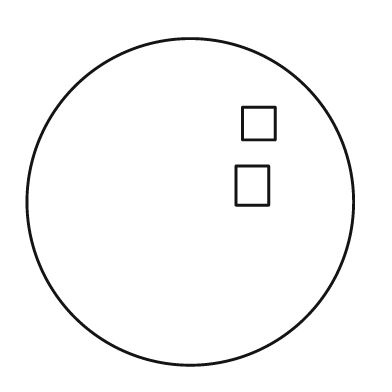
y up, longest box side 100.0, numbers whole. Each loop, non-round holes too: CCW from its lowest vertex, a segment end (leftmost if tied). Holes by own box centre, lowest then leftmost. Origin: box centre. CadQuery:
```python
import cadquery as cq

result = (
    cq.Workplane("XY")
    .moveTo(0.0, 0.0)
    .circle(50.0)
    .moveTo(14.0, -1.0)
    .lineTo(24.0, -1.0)
    .lineTo(24.0, 11.0)
    .lineTo(14.0, 11.0)
    .close()
    .moveTo(16.0, 19.0)
    .lineTo(26.0, 19.0)
    .lineTo(26.0, 29.0)
    .lineTo(16.0, 29.0)
    .close()
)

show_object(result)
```